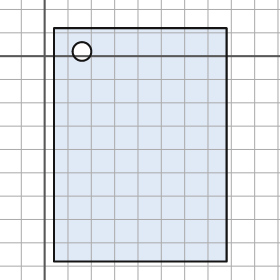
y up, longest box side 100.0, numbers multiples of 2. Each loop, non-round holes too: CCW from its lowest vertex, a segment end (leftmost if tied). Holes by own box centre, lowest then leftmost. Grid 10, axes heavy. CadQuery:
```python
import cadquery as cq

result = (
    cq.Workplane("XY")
    .moveTo(4.0, -88.0)
    .lineTo(78.0, -88.0)
    .lineTo(78.0, 12.0)
    .lineTo(4.0, 12.0)
    .close()
    .moveTo(16.0, 2.0)
    .circle(4.0)
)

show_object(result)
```